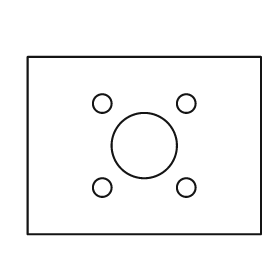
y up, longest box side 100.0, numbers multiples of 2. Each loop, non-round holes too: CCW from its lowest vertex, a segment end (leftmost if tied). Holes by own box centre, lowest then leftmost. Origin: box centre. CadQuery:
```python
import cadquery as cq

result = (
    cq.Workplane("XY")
    .moveTo(-50.0, -38.0)
    .lineTo(50.0, -38.0)
    .lineTo(50.0, 38.0)
    .lineTo(-50.0, 38.0)
    .close()
    .moveTo(-18.0, -18.0)
    .circle(4.0)
    .moveTo(18.0, -18.0)
    .circle(4.0)
    .moveTo(0.0, 0.0)
    .circle(14.0)
    .moveTo(-18.0, 18.0)
    .circle(4.0)
    .moveTo(18.0, 18.0)
    .circle(4.0)
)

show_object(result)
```